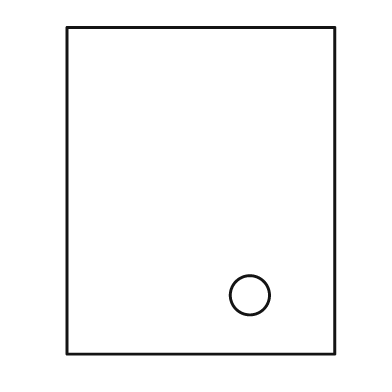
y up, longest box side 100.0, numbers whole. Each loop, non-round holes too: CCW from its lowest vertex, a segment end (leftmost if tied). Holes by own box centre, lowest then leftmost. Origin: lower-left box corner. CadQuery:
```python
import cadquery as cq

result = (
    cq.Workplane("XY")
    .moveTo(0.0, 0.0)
    .lineTo(82.0, 0.0)
    .lineTo(82.0, 100.0)
    .lineTo(0.0, 100.0)
    .close()
    .moveTo(56.0, 18.0)
    .circle(6.0)
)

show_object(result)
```